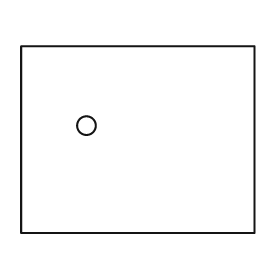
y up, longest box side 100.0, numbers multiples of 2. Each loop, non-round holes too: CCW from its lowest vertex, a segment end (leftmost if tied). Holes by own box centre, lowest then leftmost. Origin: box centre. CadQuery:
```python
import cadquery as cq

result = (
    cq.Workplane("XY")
    .moveTo(-50.0, -40.0)
    .lineTo(50.0, -40.0)
    .lineTo(50.0, 40.0)
    .lineTo(-50.0, 40.0)
    .close()
    .moveTo(-22.0, 6.0)
    .circle(4.0)
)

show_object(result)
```